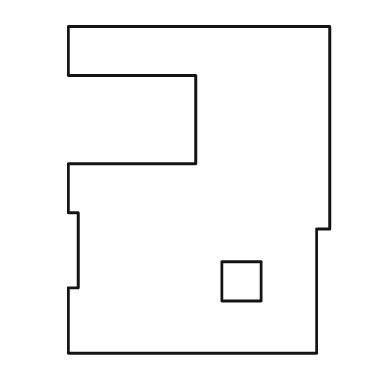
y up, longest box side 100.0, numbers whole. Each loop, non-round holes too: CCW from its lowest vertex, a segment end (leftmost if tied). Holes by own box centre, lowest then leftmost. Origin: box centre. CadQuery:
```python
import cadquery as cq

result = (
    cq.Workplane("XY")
    .moveTo(-40.0, -50.0)
    .lineTo(36.0, -50.0)
    .lineTo(36.0, -12.0)
    .lineTo(40.0, -12.0)
    .lineTo(40.0, 50.0)
    .lineTo(-40.0, 50.0)
    .lineTo(-40.0, 35.0)
    .lineTo(-1.0, 35.0)
    .lineTo(-1.0, 8.0)
    .lineTo(-40.0, 8.0)
    .lineTo(-40.0, -7.0)
    .lineTo(-37.0, -7.0)
    .lineTo(-37.0, -30.0)
    .lineTo(-40.0, -30.0)
    .close()
    .moveTo(7.0, -34.0)
    .lineTo(19.0, -34.0)
    .lineTo(19.0, -22.0)
    .lineTo(7.0, -22.0)
    .close()
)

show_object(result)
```